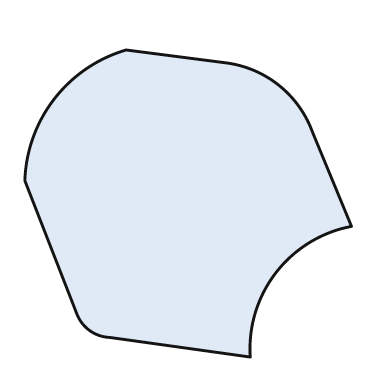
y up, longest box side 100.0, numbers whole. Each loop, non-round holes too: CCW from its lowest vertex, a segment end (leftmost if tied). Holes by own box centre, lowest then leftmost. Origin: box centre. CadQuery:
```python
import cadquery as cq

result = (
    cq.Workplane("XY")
    .moveTo(19.0, -47.0)
    .threePointArc((27.0, -21.0), (50.0, -7.0))
    .lineTo(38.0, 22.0)
    .threePointArc((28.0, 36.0), (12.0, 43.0))
    .lineTo(-19.0, 47.0)
    .threePointArc((-41.0, 32.0), (-50.0, 7.0))
    .lineTo(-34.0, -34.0)
    .threePointArc((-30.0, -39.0), (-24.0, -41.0))
    .close()
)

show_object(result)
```